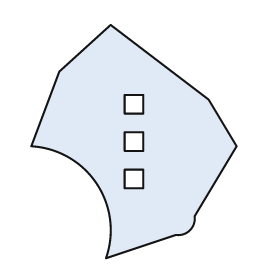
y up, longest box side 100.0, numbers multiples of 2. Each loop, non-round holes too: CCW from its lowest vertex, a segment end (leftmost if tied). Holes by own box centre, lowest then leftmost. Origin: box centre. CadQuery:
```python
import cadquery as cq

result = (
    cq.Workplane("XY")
    .moveTo(-12.0, -50.0)
    .lineTo(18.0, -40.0)
    .threePointArc((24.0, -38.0), (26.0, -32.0))
    .lineTo(44.0, -2.0)
    .lineTo(32.0, 18.0)
    .lineTo(-10.0, 50.0)
    .lineTo(-32.0, 30.0)
    .lineTo(-44.0, -2.0)
    .threePointArc((-16.0, -18.0), (-12.0, -50.0))
    .close()
    .moveTo(-4.0, -20.0)
    .lineTo(4.0, -20.0)
    .lineTo(4.0, -12.0)
    .lineTo(-4.0, -12.0)
    .close()
    .moveTo(-4.0, -4.0)
    .lineTo(4.0, -4.0)
    .lineTo(4.0, 4.0)
    .lineTo(-4.0, 4.0)
    .close()
    .moveTo(-4.0, 12.0)
    .lineTo(4.0, 12.0)
    .lineTo(4.0, 20.0)
    .lineTo(-4.0, 20.0)
    .close()
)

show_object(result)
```